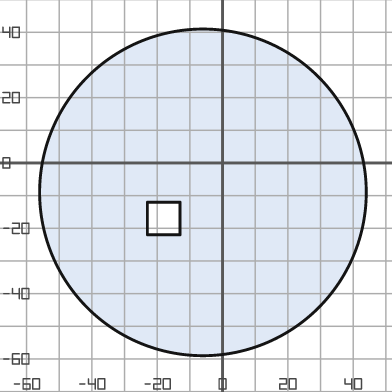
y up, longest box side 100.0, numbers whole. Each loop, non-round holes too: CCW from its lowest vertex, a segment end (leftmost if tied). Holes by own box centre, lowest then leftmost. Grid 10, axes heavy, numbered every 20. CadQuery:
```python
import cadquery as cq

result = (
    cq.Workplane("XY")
    .moveTo(-6.0, -9.0)
    .circle(50.0)
    .moveTo(-23.0, -22.0)
    .lineTo(-13.0, -22.0)
    .lineTo(-13.0, -12.0)
    .lineTo(-23.0, -12.0)
    .close()
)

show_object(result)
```